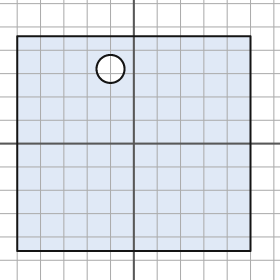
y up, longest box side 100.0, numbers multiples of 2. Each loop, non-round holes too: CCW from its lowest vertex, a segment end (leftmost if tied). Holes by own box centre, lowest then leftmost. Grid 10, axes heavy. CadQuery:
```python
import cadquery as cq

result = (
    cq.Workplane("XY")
    .moveTo(-50.0, -46.0)
    .lineTo(50.0, -46.0)
    .lineTo(50.0, 46.0)
    .lineTo(-50.0, 46.0)
    .close()
    .moveTo(-10.0, 32.0)
    .circle(6.0)
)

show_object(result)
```